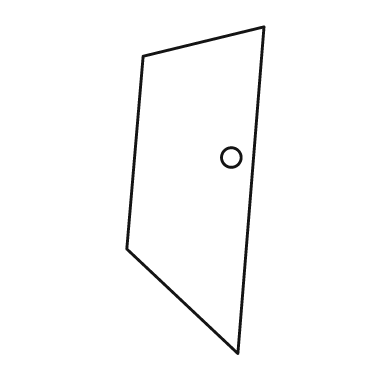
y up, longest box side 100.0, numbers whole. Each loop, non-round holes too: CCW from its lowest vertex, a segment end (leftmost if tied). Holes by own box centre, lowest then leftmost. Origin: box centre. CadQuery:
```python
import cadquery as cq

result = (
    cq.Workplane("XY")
    .moveTo(13.0, -50.0)
    .lineTo(21.0, 50.0)
    .lineTo(-16.0, 41.0)
    .lineTo(-21.0, -18.0)
    .close()
    .moveTo(11.0, 10.0)
    .circle(3.0)
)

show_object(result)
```